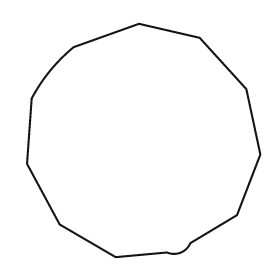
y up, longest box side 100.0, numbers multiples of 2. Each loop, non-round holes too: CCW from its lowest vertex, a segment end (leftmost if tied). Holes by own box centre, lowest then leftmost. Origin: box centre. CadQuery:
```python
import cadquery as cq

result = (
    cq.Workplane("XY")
    .moveTo(-12.0, -50.0)
    .lineTo(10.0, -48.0)
    .threePointArc((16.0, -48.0), (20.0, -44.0))
    .lineTo(40.0, -32.0)
    .lineTo(50.0, -6.0)
    .lineTo(44.0, 22.0)
    .lineTo(24.0, 44.0)
    .lineTo(-2.0, 50.0)
    .lineTo(-30.0, 40.0)
    .threePointArc((-40.0, 30.0), (-48.0, 18.0))
    .lineTo(-50.0, -10.0)
    .lineTo(-36.0, -36.0)
    .close()
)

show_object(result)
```